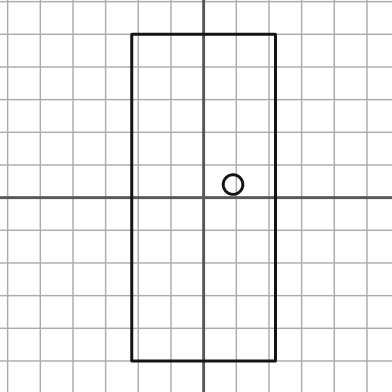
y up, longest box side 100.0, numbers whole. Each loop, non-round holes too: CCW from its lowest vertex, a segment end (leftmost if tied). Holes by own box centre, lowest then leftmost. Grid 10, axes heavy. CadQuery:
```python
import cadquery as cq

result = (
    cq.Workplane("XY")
    .moveTo(-22.0, -50.0)
    .lineTo(22.0, -50.0)
    .lineTo(22.0, 50.0)
    .lineTo(-22.0, 50.0)
    .close()
    .moveTo(9.0, 4.0)
    .circle(3.0)
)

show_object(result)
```